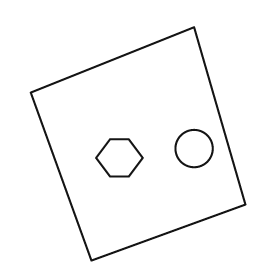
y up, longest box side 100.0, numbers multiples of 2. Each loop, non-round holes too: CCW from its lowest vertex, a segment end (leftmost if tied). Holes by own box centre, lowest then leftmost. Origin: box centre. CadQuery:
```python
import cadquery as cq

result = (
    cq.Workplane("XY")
    .moveTo(-20.0, -50.0)
    .lineTo(46.0, -26.0)
    .lineTo(24.0, 50.0)
    .lineTo(-46.0, 22.0)
    .close()
    .moveTo(-12.0, -14.0)
    .lineTo(-4.0, -14.0)
    .lineTo(2.0, -6.0)
    .lineTo(-4.0, 2.0)
    .lineTo(-12.0, 2.0)
    .lineTo(-18.0, -6.0)
    .close()
    .moveTo(24.0, -2.0)
    .circle(8.0)
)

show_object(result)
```